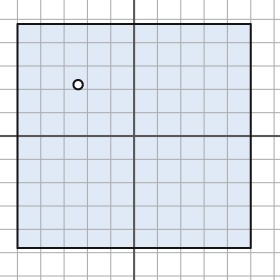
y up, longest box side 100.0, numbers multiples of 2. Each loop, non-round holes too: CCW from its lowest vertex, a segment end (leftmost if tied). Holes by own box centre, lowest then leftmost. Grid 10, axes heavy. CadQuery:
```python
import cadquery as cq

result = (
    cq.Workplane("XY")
    .moveTo(-50.0, -48.0)
    .lineTo(50.0, -48.0)
    .lineTo(50.0, 48.0)
    .lineTo(-50.0, 48.0)
    .close()
    .moveTo(-24.0, 22.0)
    .circle(2.0)
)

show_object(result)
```